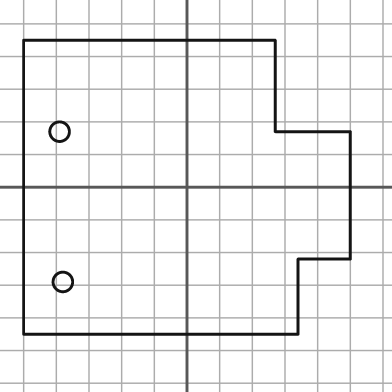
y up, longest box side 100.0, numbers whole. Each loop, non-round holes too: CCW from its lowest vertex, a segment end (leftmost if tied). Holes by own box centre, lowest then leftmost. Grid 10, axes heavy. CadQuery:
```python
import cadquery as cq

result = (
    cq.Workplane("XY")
    .moveTo(-50.0, -45.0)
    .lineTo(34.0, -45.0)
    .lineTo(34.0, -22.0)
    .lineTo(50.0, -22.0)
    .lineTo(50.0, 17.0)
    .lineTo(27.0, 17.0)
    .lineTo(27.0, 45.0)
    .lineTo(-50.0, 45.0)
    .close()
    .moveTo(-38.0, -29.0)
    .circle(3.0)
    .moveTo(-39.0, 17.0)
    .circle(3.0)
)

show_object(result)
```